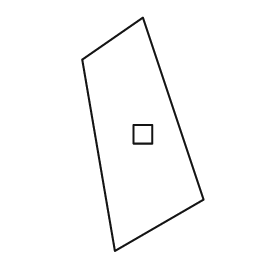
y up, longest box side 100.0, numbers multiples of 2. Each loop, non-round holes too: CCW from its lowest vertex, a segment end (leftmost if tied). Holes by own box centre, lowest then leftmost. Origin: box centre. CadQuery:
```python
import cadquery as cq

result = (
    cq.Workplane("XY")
    .moveTo(-12.0, -50.0)
    .lineTo(26.0, -28.0)
    .lineTo(0.0, 50.0)
    .lineTo(-26.0, 32.0)
    .close()
    .moveTo(-4.0, -4.0)
    .lineTo(4.0, -4.0)
    .lineTo(4.0, 4.0)
    .lineTo(-4.0, 4.0)
    .close()
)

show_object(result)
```